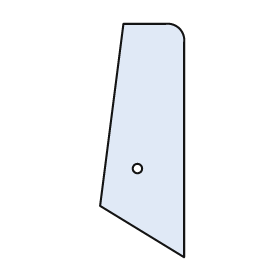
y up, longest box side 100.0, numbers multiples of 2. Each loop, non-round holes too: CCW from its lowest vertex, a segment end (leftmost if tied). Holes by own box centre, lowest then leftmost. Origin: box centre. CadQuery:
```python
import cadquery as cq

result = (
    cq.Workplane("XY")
    .moveTo(18.0, -50.0)
    .lineTo(18.0, 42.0)
    .threePointArc((16.0, 48.0), (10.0, 50.0))
    .lineTo(-8.0, 50.0)
    .lineTo(-18.0, -28.0)
    .close()
    .moveTo(-2.0, -12.0)
    .circle(2.0)
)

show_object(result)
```